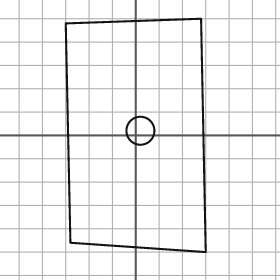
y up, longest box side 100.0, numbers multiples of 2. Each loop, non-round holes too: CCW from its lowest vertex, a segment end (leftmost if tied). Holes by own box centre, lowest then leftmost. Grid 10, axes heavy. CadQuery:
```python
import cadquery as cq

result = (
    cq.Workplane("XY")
    .moveTo(30.0, -50.0)
    .lineTo(28.0, 50.0)
    .lineTo(-30.0, 48.0)
    .lineTo(-28.0, -46.0)
    .close()
    .moveTo(2.0, 2.0)
    .circle(6.0)
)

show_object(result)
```